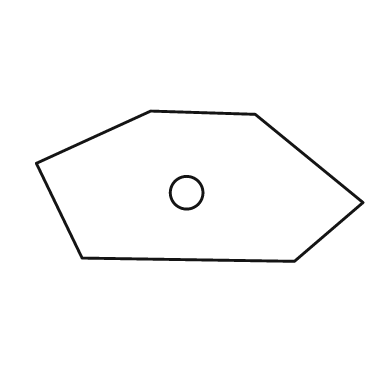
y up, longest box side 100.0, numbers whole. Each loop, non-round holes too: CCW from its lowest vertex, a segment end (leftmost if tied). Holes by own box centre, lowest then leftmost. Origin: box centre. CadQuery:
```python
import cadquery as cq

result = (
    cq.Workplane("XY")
    .moveTo(29.0, -23.0)
    .lineTo(50.0, -5.0)
    .lineTo(17.0, 22.0)
    .lineTo(-15.0, 23.0)
    .lineTo(-50.0, 7.0)
    .lineTo(-36.0, -22.0)
    .close()
    .moveTo(-4.0, -2.0)
    .circle(5.0)
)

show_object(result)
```